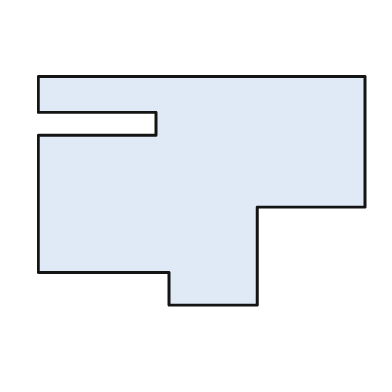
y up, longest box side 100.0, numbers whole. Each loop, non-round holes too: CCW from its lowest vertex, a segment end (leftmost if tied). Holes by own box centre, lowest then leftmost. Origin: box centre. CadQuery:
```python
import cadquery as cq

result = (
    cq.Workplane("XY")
    .moveTo(-10.0, -35.0)
    .lineTo(17.0, -35.0)
    .lineTo(17.0, -5.0)
    .lineTo(50.0, -5.0)
    .lineTo(50.0, 35.0)
    .lineTo(-50.0, 35.0)
    .lineTo(-50.0, 24.0)
    .lineTo(-14.0, 24.0)
    .lineTo(-14.0, 17.0)
    .lineTo(-50.0, 17.0)
    .lineTo(-50.0, -25.0)
    .lineTo(-10.0, -25.0)
    .close()
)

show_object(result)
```